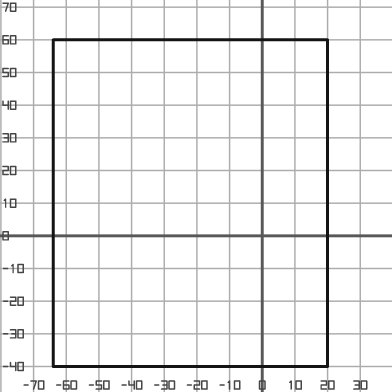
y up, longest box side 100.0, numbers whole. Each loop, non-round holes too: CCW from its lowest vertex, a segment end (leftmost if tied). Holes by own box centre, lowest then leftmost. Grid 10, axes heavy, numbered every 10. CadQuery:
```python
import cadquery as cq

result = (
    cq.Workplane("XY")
    .moveTo(-64.0, -40.0)
    .lineTo(20.0, -40.0)
    .lineTo(20.0, 60.0)
    .lineTo(-64.0, 60.0)
    .close()
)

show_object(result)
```